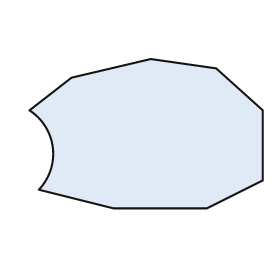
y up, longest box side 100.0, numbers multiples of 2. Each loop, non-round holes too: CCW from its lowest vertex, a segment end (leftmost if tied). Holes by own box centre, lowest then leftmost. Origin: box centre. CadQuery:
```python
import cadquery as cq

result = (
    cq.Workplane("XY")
    .moveTo(-14.0, -32.0)
    .lineTo(26.0, -32.0)
    .lineTo(50.0, -20.0)
    .lineTo(50.0, 10.0)
    .lineTo(30.0, 28.0)
    .lineTo(2.0, 32.0)
    .lineTo(-32.0, 24.0)
    .lineTo(-50.0, 10.0)
    .threePointArc((-40.0, -6.0), (-46.0, -24.0))
    .close()
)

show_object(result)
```